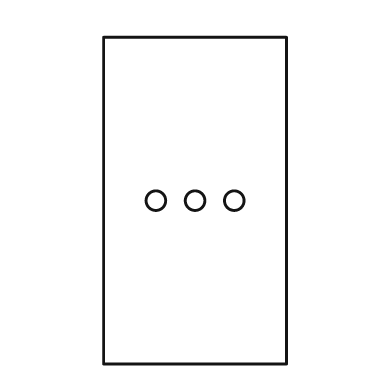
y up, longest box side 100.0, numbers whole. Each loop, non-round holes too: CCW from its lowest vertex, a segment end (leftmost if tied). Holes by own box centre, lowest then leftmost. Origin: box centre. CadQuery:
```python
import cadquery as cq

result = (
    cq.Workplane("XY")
    .moveTo(-28.0, -50.0)
    .lineTo(28.0, -50.0)
    .lineTo(28.0, 50.0)
    .lineTo(-28.0, 50.0)
    .close()
    .moveTo(-12.0, 0.0)
    .circle(3.0)
    .moveTo(0.0, 0.0)
    .circle(3.0)
    .moveTo(12.0, 0.0)
    .circle(3.0)
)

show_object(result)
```